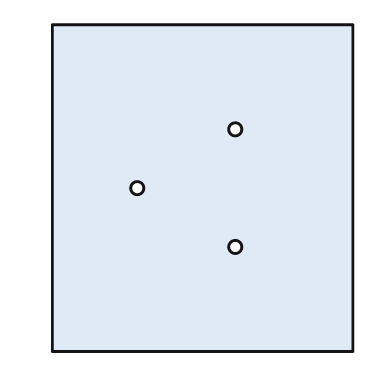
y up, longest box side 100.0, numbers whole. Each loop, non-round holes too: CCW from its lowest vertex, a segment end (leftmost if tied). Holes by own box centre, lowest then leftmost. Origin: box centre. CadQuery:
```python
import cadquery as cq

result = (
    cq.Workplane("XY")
    .moveTo(-46.0, -50.0)
    .lineTo(46.0, -50.0)
    .lineTo(46.0, 50.0)
    .lineTo(-46.0, 50.0)
    .close()
    .moveTo(10.0, -18.0)
    .circle(2.0)
    .moveTo(-20.0, 0.0)
    .circle(2.0)
    .moveTo(10.0, 18.0)
    .circle(2.0)
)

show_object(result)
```